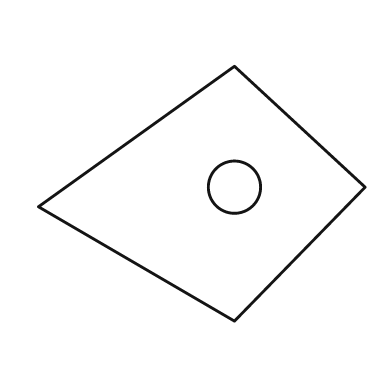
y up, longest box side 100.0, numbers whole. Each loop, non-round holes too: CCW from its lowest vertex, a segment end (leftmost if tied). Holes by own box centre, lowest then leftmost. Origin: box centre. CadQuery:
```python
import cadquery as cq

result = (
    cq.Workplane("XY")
    .moveTo(10.0, -39.0)
    .lineTo(50.0, 2.0)
    .lineTo(10.0, 39.0)
    .lineTo(-50.0, -4.0)
    .close()
    .moveTo(10.0, 2.0)
    .circle(8.0)
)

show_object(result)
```